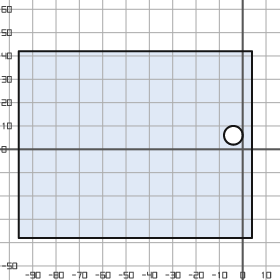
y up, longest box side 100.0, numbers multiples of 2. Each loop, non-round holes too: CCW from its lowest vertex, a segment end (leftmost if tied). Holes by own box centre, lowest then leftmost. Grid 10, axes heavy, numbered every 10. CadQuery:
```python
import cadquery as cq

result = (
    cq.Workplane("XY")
    .moveTo(-96.0, -38.0)
    .lineTo(4.0, -38.0)
    .lineTo(4.0, 42.0)
    .lineTo(-96.0, 42.0)
    .close()
    .moveTo(-4.0, 6.0)
    .circle(4.0)
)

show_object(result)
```